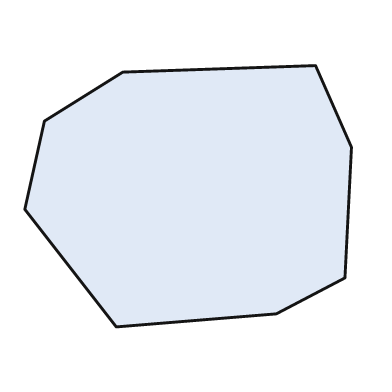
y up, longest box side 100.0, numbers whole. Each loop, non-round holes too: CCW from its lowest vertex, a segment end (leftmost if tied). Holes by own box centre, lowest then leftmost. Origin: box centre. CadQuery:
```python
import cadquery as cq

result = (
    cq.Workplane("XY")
    .moveTo(-22.0, -40.0)
    .lineTo(27.0, -36.0)
    .lineTo(48.0, -25.0)
    .lineTo(50.0, 15.0)
    .lineTo(39.0, 40.0)
    .lineTo(-20.0, 38.0)
    .lineTo(-44.0, 23.0)
    .lineTo(-50.0, -4.0)
    .close()
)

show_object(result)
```